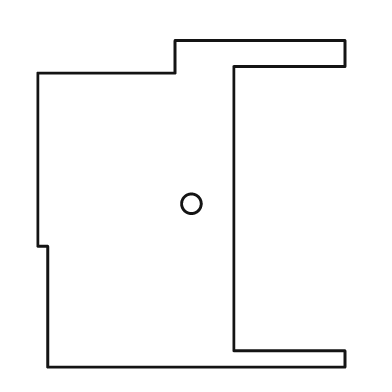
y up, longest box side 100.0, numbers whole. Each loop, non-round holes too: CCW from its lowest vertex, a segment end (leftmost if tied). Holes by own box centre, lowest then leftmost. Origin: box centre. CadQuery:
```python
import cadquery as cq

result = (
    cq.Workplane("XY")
    .moveTo(-44.0, -50.0)
    .lineTo(47.0, -50.0)
    .lineTo(47.0, -45.0)
    .lineTo(13.0, -45.0)
    .lineTo(13.0, 42.0)
    .lineTo(47.0, 42.0)
    .lineTo(47.0, 50.0)
    .lineTo(-5.0, 50.0)
    .lineTo(-5.0, 40.0)
    .lineTo(-47.0, 40.0)
    .lineTo(-47.0, -13.0)
    .lineTo(-44.0, -13.0)
    .close()
    .moveTo(0.0, 0.0)
    .circle(3.0)
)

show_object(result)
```